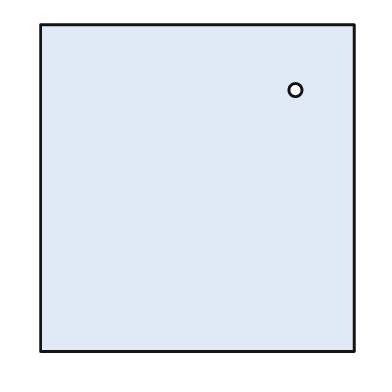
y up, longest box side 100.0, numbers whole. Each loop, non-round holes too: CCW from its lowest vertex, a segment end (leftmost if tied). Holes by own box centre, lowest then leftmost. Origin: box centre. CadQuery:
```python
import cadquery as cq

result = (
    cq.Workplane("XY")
    .moveTo(-48.0, -50.0)
    .lineTo(48.0, -50.0)
    .lineTo(48.0, 50.0)
    .lineTo(-48.0, 50.0)
    .close()
    .moveTo(30.0, 30.0)
    .circle(2.0)
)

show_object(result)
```